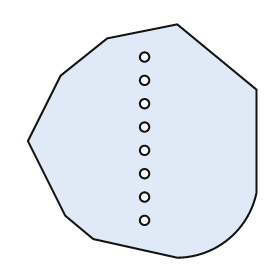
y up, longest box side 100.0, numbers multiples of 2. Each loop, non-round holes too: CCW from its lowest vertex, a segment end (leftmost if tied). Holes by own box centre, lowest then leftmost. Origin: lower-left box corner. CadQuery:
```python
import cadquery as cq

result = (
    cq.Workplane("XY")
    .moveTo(64.0, 0.0)
    .threePointArc((86.0, 8.0), (98.0, 28.0))
    .lineTo(98.0, 72.0)
    .lineTo(64.0, 100.0)
    .lineTo(34.0, 94.0)
    .lineTo(14.0, 78.0)
    .lineTo(0.0, 50.0)
    .lineTo(16.0, 18.0)
    .lineTo(28.0, 8.0)
    .close()
    .moveTo(50.0, 16.0)
    .circle(2.0)
    .moveTo(50.0, 26.0)
    .circle(2.0)
    .moveTo(50.0, 36.0)
    .circle(2.0)
    .moveTo(50.0, 46.0)
    .circle(2.0)
    .moveTo(50.0, 56.0)
    .circle(2.0)
    .moveTo(50.0, 66.0)
    .circle(2.0)
    .moveTo(50.0, 76.0)
    .circle(2.0)
    .moveTo(50.0, 86.0)
    .circle(2.0)
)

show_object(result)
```